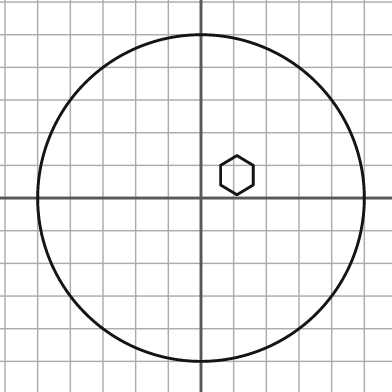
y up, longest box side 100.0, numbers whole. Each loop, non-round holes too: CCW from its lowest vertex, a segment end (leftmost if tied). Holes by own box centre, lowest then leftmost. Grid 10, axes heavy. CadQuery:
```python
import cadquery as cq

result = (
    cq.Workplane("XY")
    .moveTo(0.0, 0.0)
    .circle(50.0)
    .moveTo(11.0, 1.0)
    .lineTo(16.0, 4.0)
    .lineTo(16.0, 10.0)
    .lineTo(11.0, 13.0)
    .lineTo(6.0, 10.0)
    .lineTo(6.0, 4.0)
    .close()
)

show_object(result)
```